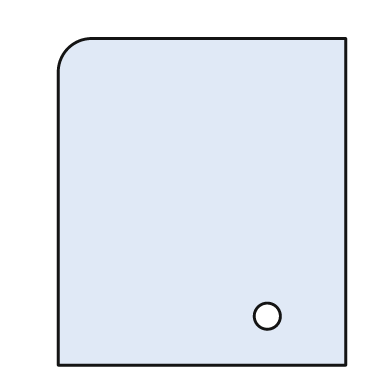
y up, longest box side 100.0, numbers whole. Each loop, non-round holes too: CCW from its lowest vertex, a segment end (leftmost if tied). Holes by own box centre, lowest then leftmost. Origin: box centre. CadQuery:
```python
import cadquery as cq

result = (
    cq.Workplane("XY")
    .moveTo(-44.0, -50.0)
    .lineTo(44.0, -50.0)
    .lineTo(44.0, 50.0)
    .lineTo(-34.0, 50.0)
    .threePointArc((-41.0, 47.0), (-44.0, 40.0))
    .close()
    .moveTo(20.0, -35.0)
    .circle(4.0)
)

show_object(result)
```